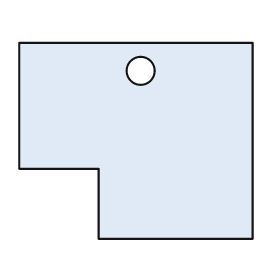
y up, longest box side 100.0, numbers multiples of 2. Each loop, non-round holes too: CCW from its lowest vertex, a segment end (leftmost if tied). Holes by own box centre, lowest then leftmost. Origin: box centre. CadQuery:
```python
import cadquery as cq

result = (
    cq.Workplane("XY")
    .moveTo(-16.0, -42.0)
    .lineTo(50.0, -42.0)
    .lineTo(50.0, 42.0)
    .lineTo(-50.0, 42.0)
    .lineTo(-50.0, -12.0)
    .lineTo(-16.0, -12.0)
    .close()
    .moveTo(2.0, 30.0)
    .circle(6.0)
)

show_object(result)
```